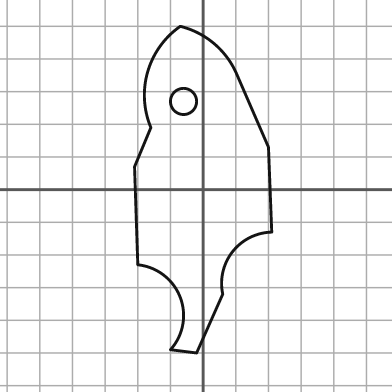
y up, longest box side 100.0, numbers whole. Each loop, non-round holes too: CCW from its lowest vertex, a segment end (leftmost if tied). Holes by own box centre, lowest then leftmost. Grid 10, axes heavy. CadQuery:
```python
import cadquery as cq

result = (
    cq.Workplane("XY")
    .moveTo(-2.0, -50.0)
    .lineTo(6.0, -32.0)
    .threePointArc((9.0, -19.0), (21.0, -13.0))
    .lineTo(20.0, 13.0)
    .lineTo(10.0, 36.0)
    .threePointArc((3.0, 45.0), (-7.0, 50.0))
    .threePointArc((-17.0, 36.0), (-16.0, 19.0))
    .lineTo(-21.0, 7.0)
    .lineTo(-20.0, -23.0)
    .threePointArc((-7.0, -33.0), (-10.0, -49.0))
    .close()
    .moveTo(-6.0, 27.0)
    .circle(4.0)
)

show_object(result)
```